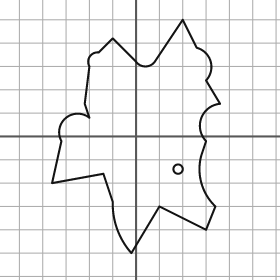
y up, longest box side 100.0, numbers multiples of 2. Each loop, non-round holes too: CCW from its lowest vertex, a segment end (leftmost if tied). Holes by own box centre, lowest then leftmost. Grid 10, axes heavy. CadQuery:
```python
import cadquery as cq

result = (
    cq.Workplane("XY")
    .moveTo(-2.0, -50.0)
    .lineTo(10.0, -30.0)
    .lineTo(30.0, -40.0)
    .lineTo(34.0, -30.0)
    .threePointArc((28.0, -20.0), (28.0, -8.0))
    .lineTo(30.0, -2.0)
    .threePointArc((28.0, 8.0), (36.0, 14.0))
    .lineTo(30.0, 24.0)
    .threePointArc((32.0, 32.0), (26.0, 38.0))
    .lineTo(20.0, 50.0)
    .lineTo(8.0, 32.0)
    .threePointArc((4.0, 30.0), (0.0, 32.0))
    .lineTo(-10.0, 42.0)
    .lineTo(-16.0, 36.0)
    .threePointArc((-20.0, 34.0), (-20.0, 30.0))
    .lineTo(-22.0, 14.0)
    .lineTo(-20.0, 8.0)
    .threePointArc((-30.0, 8.0), (-32.0, -2.0))
    .lineTo(-36.0, -20.0)
    .lineTo(-14.0, -16.0)
    .lineTo(-10.0, -28.0)
    .threePointArc((-8.0, -40.0), (-2.0, -50.0))
    .close()
    .moveTo(18.0, -14.0)
    .circle(2.0)
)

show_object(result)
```